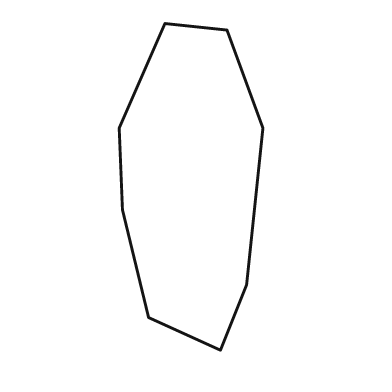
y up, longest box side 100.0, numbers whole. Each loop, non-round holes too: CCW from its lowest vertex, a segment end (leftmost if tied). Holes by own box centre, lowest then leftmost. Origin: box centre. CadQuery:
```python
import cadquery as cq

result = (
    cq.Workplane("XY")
    .moveTo(9.0, -50.0)
    .lineTo(17.0, -30.0)
    .lineTo(22.0, 18.0)
    .lineTo(11.0, 48.0)
    .lineTo(-8.0, 50.0)
    .lineTo(-22.0, 18.0)
    .lineTo(-21.0, -7.0)
    .lineTo(-13.0, -40.0)
    .close()
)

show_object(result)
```